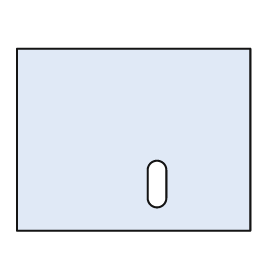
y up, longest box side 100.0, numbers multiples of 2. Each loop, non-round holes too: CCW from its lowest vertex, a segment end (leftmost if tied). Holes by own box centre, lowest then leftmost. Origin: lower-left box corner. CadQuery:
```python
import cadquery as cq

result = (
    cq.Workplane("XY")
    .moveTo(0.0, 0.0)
    .lineTo(100.0, 0.0)
    .lineTo(100.0, 78.0)
    .lineTo(0.0, 78.0)
    .close()
    .moveTo(56.0, 14.0)
    .threePointArc((60.0, 10.0), (64.0, 14.0))
    .lineTo(64.0, 26.0)
    .threePointArc((60.0, 30.0), (56.0, 26.0))
    .close()
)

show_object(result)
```